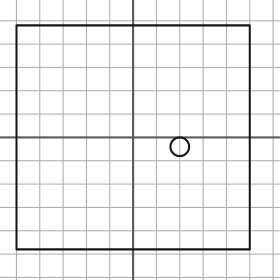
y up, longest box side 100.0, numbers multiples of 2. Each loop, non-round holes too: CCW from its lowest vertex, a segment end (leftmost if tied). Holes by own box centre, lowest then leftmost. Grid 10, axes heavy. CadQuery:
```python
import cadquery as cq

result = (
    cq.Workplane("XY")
    .moveTo(-50.0, -48.0)
    .lineTo(50.0, -48.0)
    .lineTo(50.0, 48.0)
    .lineTo(-50.0, 48.0)
    .close()
    .moveTo(20.0, -4.0)
    .circle(4.0)
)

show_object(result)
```